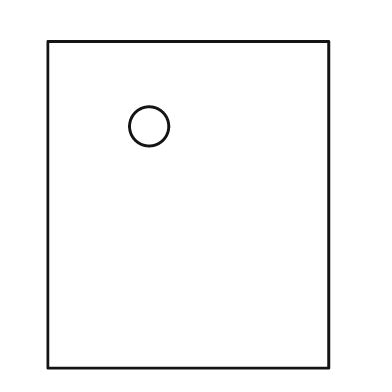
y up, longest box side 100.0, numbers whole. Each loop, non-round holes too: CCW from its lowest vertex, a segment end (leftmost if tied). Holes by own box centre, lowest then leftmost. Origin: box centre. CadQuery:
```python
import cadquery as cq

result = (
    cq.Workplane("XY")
    .moveTo(-43.0, -50.0)
    .lineTo(43.0, -50.0)
    .lineTo(43.0, 50.0)
    .lineTo(-43.0, 50.0)
    .close()
    .moveTo(-12.0, 24.0)
    .circle(6.0)
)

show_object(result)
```